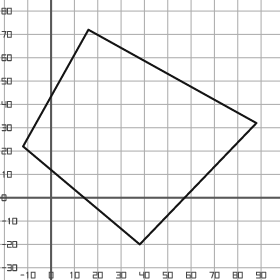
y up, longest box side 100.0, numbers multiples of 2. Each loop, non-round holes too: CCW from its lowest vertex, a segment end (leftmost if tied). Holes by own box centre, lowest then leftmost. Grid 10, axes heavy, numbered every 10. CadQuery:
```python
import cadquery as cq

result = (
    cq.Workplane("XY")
    .moveTo(38.0, -20.0)
    .lineTo(88.0, 32.0)
    .lineTo(16.0, 72.0)
    .lineTo(-12.0, 22.0)
    .close()
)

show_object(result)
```